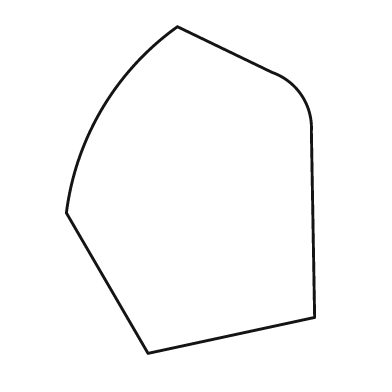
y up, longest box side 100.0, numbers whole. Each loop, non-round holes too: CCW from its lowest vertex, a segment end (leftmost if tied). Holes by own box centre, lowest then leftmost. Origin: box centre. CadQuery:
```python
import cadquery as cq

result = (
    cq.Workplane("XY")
    .moveTo(-13.0, -50.0)
    .lineTo(38.0, -39.0)
    .lineTo(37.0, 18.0)
    .threePointArc((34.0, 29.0), (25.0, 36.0))
    .lineTo(-4.0, 50.0)
    .threePointArc((-27.0, 25.0), (-38.0, -7.0))
    .close()
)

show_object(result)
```